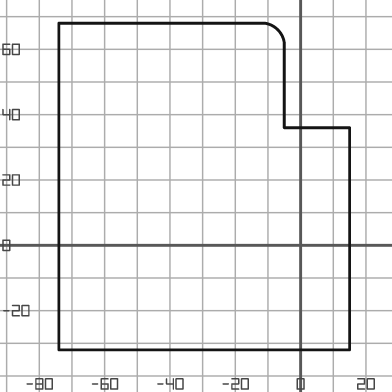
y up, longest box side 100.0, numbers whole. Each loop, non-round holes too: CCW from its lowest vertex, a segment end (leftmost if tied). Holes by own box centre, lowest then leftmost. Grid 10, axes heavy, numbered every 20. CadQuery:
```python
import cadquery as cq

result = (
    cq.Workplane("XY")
    .moveTo(-74.0, -32.0)
    .lineTo(15.0, -32.0)
    .lineTo(15.0, 36.0)
    .lineTo(-5.0, 36.0)
    .lineTo(-5.0, 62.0)
    .threePointArc((-7.0, 66.0), (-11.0, 68.0))
    .lineTo(-74.0, 68.0)
    .close()
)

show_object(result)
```